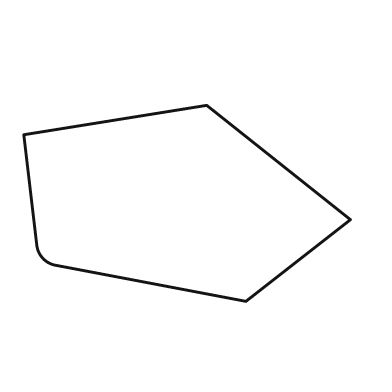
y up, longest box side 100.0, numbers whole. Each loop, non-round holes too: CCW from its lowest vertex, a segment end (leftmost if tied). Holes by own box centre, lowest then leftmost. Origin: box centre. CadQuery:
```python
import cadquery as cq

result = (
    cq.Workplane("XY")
    .moveTo(18.0, -30.0)
    .lineTo(50.0, -5.0)
    .lineTo(6.0, 30.0)
    .lineTo(-50.0, 21.0)
    .lineTo(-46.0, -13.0)
    .threePointArc((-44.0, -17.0), (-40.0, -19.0))
    .close()
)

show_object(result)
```